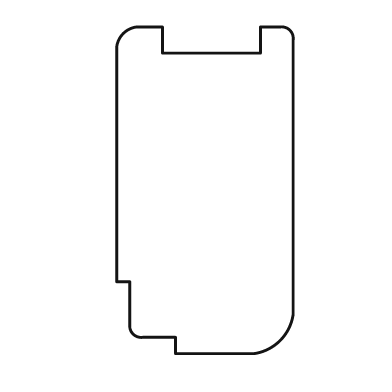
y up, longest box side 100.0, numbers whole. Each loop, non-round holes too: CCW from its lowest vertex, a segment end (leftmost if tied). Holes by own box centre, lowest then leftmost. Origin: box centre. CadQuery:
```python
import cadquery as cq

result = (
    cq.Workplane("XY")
    .moveTo(-9.0, -50.0)
    .lineTo(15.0, -50.0)
    .threePointArc((23.0, -46.0), (27.0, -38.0))
    .lineTo(27.0, 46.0)
    .threePointArc((26.0, 49.0), (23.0, 50.0))
    .lineTo(17.0, 50.0)
    .lineTo(17.0, 42.0)
    .lineTo(-13.0, 42.0)
    .lineTo(-13.0, 50.0)
    .lineTo(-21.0, 50.0)
    .threePointArc((-25.0, 48.0), (-27.0, 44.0))
    .lineTo(-27.0, -28.0)
    .lineTo(-23.0, -28.0)
    .lineTo(-23.0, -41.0)
    .threePointArc((-22.0, -44.0), (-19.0, -45.0))
    .lineTo(-9.0, -45.0)
    .close()
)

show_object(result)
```